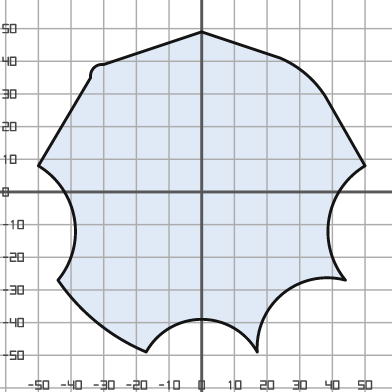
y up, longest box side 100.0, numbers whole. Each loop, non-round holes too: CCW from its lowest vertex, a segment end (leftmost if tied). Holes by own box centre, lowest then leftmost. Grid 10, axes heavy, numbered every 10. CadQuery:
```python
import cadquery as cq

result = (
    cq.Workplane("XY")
    .moveTo(-17.0, -49.0)
    .threePointArc((0.0, -39.0), (17.0, -49.0))
    .threePointArc((25.0, -31.0), (44.0, -27.0))
    .threePointArc((39.0, -8.0), (50.0, 8.0))
    .lineTo(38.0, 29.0)
    .threePointArc((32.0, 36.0), (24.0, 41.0))
    .lineTo(0.0, 49.0)
    .lineTo(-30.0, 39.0)
    .threePointArc((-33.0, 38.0), (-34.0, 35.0))
    .lineTo(-50.0, 8.0)
    .threePointArc((-39.0, -8.0), (-44.0, -27.0))
    .threePointArc((-32.0, -40.0), (-17.0, -49.0))
    .close()
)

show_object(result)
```